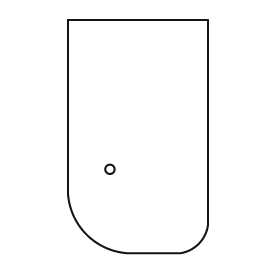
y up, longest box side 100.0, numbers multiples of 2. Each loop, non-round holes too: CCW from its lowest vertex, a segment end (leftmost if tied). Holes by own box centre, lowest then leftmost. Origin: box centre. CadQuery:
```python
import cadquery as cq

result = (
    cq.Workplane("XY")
    .moveTo(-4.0, -50.0)
    .lineTo(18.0, -50.0)
    .threePointArc((26.0, -46.0), (30.0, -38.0))
    .lineTo(30.0, 50.0)
    .lineTo(-30.0, 50.0)
    .lineTo(-30.0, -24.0)
    .threePointArc((-22.0, -42.0), (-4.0, -50.0))
    .close()
    .moveTo(-12.0, -14.0)
    .circle(2.0)
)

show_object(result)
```